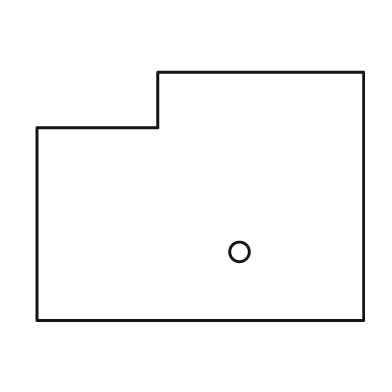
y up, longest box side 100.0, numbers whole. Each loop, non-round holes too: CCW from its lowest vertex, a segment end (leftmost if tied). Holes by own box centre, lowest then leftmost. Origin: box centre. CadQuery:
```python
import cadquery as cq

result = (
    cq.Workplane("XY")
    .moveTo(-50.0, -38.0)
    .lineTo(50.0, -38.0)
    .lineTo(50.0, 38.0)
    .lineTo(-13.0, 38.0)
    .lineTo(-13.0, 21.0)
    .lineTo(-50.0, 21.0)
    .close()
    .moveTo(12.0, -17.0)
    .circle(3.0)
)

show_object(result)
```